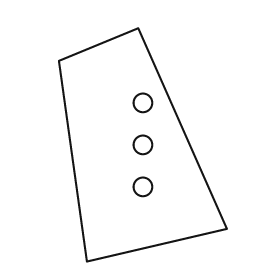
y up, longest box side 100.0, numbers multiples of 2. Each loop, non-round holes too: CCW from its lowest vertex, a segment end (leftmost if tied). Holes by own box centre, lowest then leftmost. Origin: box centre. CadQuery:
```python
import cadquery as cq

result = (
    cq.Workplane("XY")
    .moveTo(-24.0, -50.0)
    .lineTo(36.0, -36.0)
    .lineTo(-2.0, 50.0)
    .lineTo(-36.0, 36.0)
    .close()
    .moveTo(0.0, -18.0)
    .circle(4.0)
    .moveTo(0.0, 0.0)
    .circle(4.0)
    .moveTo(0.0, 18.0)
    .circle(4.0)
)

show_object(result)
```